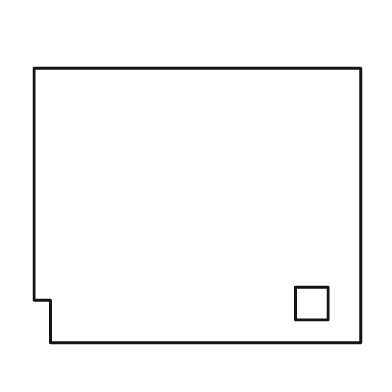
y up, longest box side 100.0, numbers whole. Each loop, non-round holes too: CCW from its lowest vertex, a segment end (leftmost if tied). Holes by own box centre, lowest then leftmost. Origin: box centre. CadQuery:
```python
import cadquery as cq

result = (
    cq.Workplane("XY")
    .moveTo(-45.0, -42.0)
    .lineTo(50.0, -42.0)
    .lineTo(50.0, 42.0)
    .lineTo(-50.0, 42.0)
    .lineTo(-50.0, -29.0)
    .lineTo(-45.0, -29.0)
    .close()
    .moveTo(30.0, -35.0)
    .lineTo(40.0, -35.0)
    .lineTo(40.0, -25.0)
    .lineTo(30.0, -25.0)
    .close()
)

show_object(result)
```